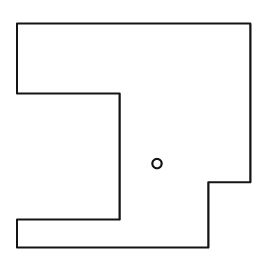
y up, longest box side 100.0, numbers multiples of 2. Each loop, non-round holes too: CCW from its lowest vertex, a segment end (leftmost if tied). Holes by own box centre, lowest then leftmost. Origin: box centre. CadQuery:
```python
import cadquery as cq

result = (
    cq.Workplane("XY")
    .moveTo(-50.0, -48.0)
    .lineTo(32.0, -48.0)
    .lineTo(32.0, -20.0)
    .lineTo(50.0, -20.0)
    .lineTo(50.0, 48.0)
    .lineTo(-50.0, 48.0)
    .lineTo(-50.0, 18.0)
    .lineTo(-6.0, 18.0)
    .lineTo(-6.0, -36.0)
    .lineTo(-50.0, -36.0)
    .close()
    .moveTo(10.0, -12.0)
    .circle(2.0)
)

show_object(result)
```